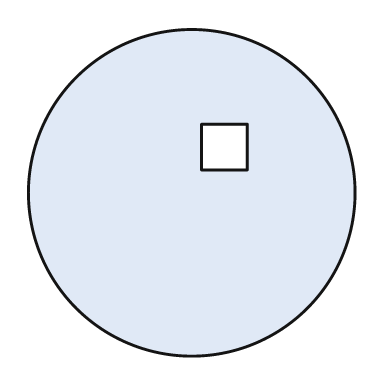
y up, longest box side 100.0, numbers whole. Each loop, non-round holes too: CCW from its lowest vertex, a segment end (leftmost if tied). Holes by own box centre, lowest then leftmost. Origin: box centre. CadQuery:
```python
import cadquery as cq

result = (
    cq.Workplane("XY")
    .moveTo(0.0, 0.0)
    .circle(50.0)
    .moveTo(3.0, 7.0)
    .lineTo(17.0, 7.0)
    .lineTo(17.0, 21.0)
    .lineTo(3.0, 21.0)
    .close()
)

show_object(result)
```